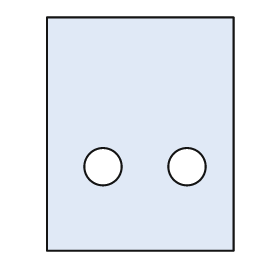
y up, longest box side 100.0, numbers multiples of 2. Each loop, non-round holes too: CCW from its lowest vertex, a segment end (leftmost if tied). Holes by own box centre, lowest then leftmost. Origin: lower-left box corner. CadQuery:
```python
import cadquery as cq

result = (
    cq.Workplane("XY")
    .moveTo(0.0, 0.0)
    .lineTo(80.0, 0.0)
    .lineTo(80.0, 100.0)
    .lineTo(0.0, 100.0)
    .close()
    .moveTo(24.0, 36.0)
    .circle(8.0)
    .moveTo(60.0, 36.0)
    .circle(8.0)
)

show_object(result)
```